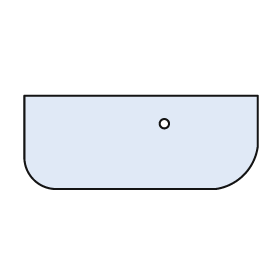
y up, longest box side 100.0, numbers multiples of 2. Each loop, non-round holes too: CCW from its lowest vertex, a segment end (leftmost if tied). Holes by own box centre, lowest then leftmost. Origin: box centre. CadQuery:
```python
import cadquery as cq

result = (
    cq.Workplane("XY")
    .moveTo(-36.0, -20.0)
    .lineTo(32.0, -20.0)
    .threePointArc((44.0, -14.0), (50.0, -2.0))
    .lineTo(50.0, 20.0)
    .lineTo(-50.0, 20.0)
    .lineTo(-50.0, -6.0)
    .threePointArc((-46.0, -16.0), (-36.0, -20.0))
    .close()
    .moveTo(10.0, 8.0)
    .circle(2.0)
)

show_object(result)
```